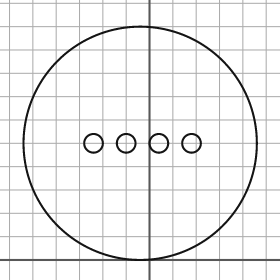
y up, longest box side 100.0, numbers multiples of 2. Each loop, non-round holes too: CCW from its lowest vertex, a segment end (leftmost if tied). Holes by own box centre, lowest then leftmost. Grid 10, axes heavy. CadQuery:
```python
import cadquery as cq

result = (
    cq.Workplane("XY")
    .moveTo(-4.0, 50.0)
    .circle(50.0)
    .moveTo(-24.0, 50.0)
    .circle(4.0)
    .moveTo(-10.0, 50.0)
    .circle(4.0)
    .moveTo(4.0, 50.0)
    .circle(4.0)
    .moveTo(18.0, 50.0)
    .circle(4.0)
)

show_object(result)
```